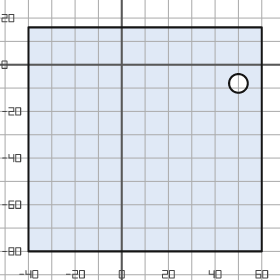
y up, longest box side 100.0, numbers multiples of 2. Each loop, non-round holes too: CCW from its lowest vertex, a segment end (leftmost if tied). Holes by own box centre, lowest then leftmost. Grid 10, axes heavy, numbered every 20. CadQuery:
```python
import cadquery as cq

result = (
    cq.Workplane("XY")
    .moveTo(-40.0, -80.0)
    .lineTo(60.0, -80.0)
    .lineTo(60.0, 16.0)
    .lineTo(-40.0, 16.0)
    .close()
    .moveTo(50.0, -8.0)
    .circle(4.0)
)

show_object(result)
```